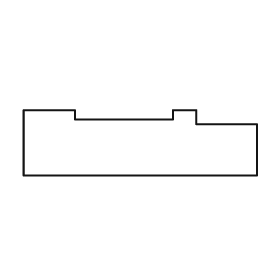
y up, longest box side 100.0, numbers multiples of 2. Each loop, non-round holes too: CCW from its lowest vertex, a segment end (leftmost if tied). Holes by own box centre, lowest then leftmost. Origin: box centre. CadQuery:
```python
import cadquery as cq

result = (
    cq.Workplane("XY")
    .moveTo(-50.0, -14.0)
    .lineTo(50.0, -14.0)
    .lineTo(50.0, 8.0)
    .lineTo(24.0, 8.0)
    .lineTo(24.0, 14.0)
    .lineTo(14.0, 14.0)
    .lineTo(14.0, 10.0)
    .lineTo(-28.0, 10.0)
    .lineTo(-28.0, 14.0)
    .lineTo(-50.0, 14.0)
    .close()
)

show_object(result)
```